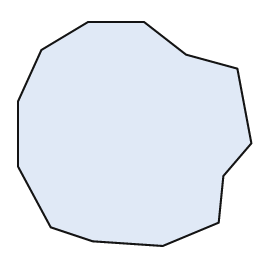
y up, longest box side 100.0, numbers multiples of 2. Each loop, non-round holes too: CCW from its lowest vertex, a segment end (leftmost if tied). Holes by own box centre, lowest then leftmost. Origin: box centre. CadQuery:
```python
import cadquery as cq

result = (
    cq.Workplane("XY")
    .moveTo(12.0, -48.0)
    .lineTo(36.0, -38.0)
    .lineTo(38.0, -18.0)
    .lineTo(50.0, -4.0)
    .lineTo(44.0, 28.0)
    .lineTo(22.0, 34.0)
    .lineTo(4.0, 48.0)
    .lineTo(-20.0, 48.0)
    .lineTo(-40.0, 36.0)
    .lineTo(-50.0, 14.0)
    .lineTo(-50.0, -14.0)
    .lineTo(-36.0, -40.0)
    .lineTo(-18.0, -46.0)
    .close()
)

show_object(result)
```